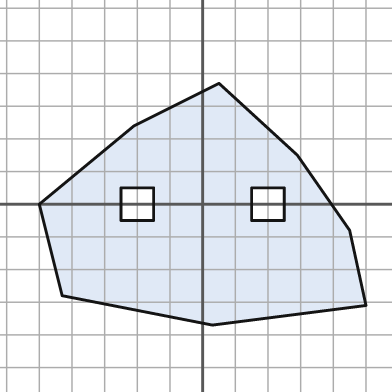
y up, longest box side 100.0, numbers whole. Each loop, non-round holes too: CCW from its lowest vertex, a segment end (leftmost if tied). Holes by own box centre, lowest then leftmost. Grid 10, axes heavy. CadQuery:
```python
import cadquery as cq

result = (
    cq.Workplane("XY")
    .moveTo(3.0, -37.0)
    .lineTo(50.0, -31.0)
    .lineTo(45.0, -8.0)
    .lineTo(29.0, 15.0)
    .lineTo(5.0, 37.0)
    .lineTo(-21.0, 24.0)
    .lineTo(-50.0, 0.0)
    .lineTo(-43.0, -28.0)
    .close()
    .moveTo(-25.0, -5.0)
    .lineTo(-15.0, -5.0)
    .lineTo(-15.0, 5.0)
    .lineTo(-25.0, 5.0)
    .close()
    .moveTo(15.0, -5.0)
    .lineTo(25.0, -5.0)
    .lineTo(25.0, 5.0)
    .lineTo(15.0, 5.0)
    .close()
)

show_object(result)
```